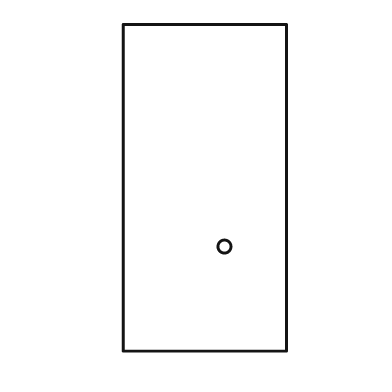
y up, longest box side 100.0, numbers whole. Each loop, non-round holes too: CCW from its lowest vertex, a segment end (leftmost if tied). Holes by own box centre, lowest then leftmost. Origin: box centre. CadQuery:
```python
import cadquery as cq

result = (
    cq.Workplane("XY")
    .moveTo(-25.0, -50.0)
    .lineTo(25.0, -50.0)
    .lineTo(25.0, 50.0)
    .lineTo(-25.0, 50.0)
    .close()
    .moveTo(6.0, -18.0)
    .circle(2.0)
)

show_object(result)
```